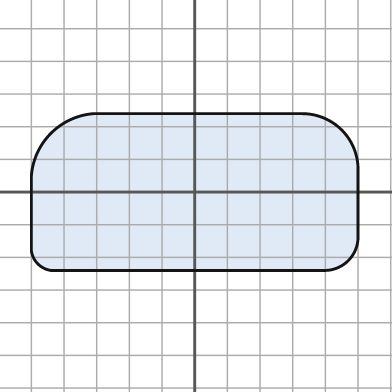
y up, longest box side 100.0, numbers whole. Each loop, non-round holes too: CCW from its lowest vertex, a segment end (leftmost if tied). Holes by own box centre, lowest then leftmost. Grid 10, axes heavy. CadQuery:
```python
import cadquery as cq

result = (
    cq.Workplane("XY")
    .moveTo(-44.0, -24.0)
    .lineTo(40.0, -24.0)
    .threePointArc((47.0, -21.0), (50.0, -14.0))
    .lineTo(50.0, 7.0)
    .threePointArc((45.0, 19.0), (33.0, 24.0))
    .lineTo(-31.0, 24.0)
    .threePointArc((-44.0, 18.0), (-50.0, 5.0))
    .lineTo(-50.0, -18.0)
    .threePointArc((-48.0, -22.0), (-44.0, -24.0))
    .close()
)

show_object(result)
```